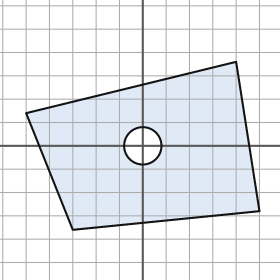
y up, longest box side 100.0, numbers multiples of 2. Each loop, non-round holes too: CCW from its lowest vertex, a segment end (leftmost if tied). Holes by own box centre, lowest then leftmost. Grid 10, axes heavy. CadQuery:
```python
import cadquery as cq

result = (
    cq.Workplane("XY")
    .moveTo(-30.0, -36.0)
    .lineTo(50.0, -28.0)
    .lineTo(40.0, 36.0)
    .lineTo(-50.0, 14.0)
    .close()
    .moveTo(0.0, 0.0)
    .circle(8.0)
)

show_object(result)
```